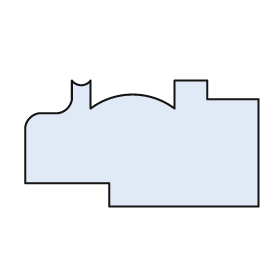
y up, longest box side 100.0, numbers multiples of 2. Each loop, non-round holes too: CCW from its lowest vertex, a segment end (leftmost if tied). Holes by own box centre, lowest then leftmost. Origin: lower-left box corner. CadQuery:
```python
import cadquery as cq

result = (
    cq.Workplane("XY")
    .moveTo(36.0, 0.0)
    .lineTo(100.0, 0.0)
    .lineTo(100.0, 46.0)
    .lineTo(78.0, 46.0)
    .lineTo(78.0, 54.0)
    .lineTo(64.0, 54.0)
    .lineTo(64.0, 42.0)
    .threePointArc((46.0, 48.0), (28.0, 42.0))
    .lineTo(28.0, 54.0)
    .threePointArc((24.0, 52.0), (20.0, 54.0))
    .lineTo(20.0, 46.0)
    .threePointArc((18.0, 42.0), (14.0, 40.0))
    .lineTo(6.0, 40.0)
    .threePointArc((2.0, 38.0), (0.0, 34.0))
    .lineTo(0.0, 10.0)
    .lineTo(36.0, 10.0)
    .close()
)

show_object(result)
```